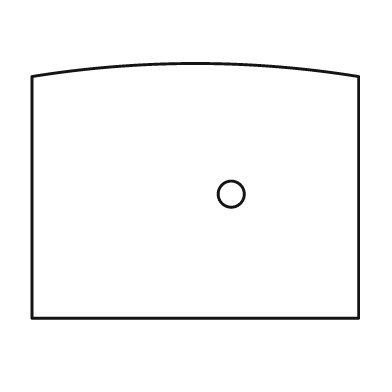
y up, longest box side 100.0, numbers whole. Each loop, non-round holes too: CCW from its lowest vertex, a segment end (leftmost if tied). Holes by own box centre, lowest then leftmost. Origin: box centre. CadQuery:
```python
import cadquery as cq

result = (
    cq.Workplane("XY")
    .moveTo(-50.0, -39.0)
    .lineTo(50.0, -39.0)
    .lineTo(50.0, 35.0)
    .threePointArc((0.0, 39.0), (-50.0, 35.0))
    .close()
    .moveTo(11.0, -1.0)
    .circle(4.0)
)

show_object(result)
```